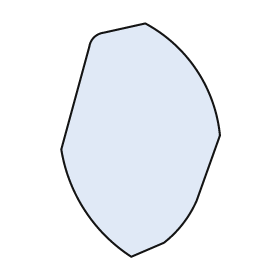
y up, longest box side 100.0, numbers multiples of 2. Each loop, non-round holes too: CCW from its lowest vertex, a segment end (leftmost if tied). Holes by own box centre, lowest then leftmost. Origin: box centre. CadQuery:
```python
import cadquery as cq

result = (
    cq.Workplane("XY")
    .moveTo(-4.0, -50.0)
    .lineTo(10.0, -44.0)
    .threePointArc((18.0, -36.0), (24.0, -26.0))
    .lineTo(34.0, 2.0)
    .threePointArc((24.0, 30.0), (2.0, 50.0))
    .lineTo(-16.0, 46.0)
    .threePointArc((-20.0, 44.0), (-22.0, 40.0))
    .lineTo(-34.0, -4.0)
    .threePointArc((-24.0, -30.0), (-4.0, -50.0))
    .close()
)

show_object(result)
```